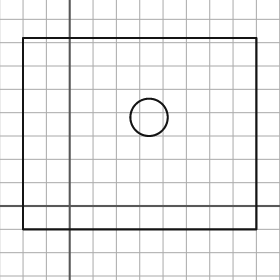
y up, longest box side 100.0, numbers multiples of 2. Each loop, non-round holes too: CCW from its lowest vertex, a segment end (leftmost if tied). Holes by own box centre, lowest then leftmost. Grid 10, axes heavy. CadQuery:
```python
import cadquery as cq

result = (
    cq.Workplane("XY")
    .moveTo(-20.0, -10.0)
    .lineTo(80.0, -10.0)
    .lineTo(80.0, 72.0)
    .lineTo(-20.0, 72.0)
    .close()
    .moveTo(34.0, 38.0)
    .circle(8.0)
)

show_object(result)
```